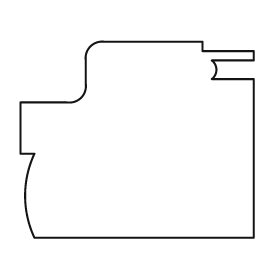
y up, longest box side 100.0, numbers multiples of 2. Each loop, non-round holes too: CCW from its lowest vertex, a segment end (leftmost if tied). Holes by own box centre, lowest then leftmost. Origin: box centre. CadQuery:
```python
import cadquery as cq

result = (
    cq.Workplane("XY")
    .moveTo(-44.0, -42.0)
    .lineTo(50.0, -42.0)
    .lineTo(50.0, 26.0)
    .lineTo(32.0, 26.0)
    .threePointArc((34.0, 30.0), (32.0, 34.0))
    .lineTo(50.0, 34.0)
    .lineTo(50.0, 38.0)
    .lineTo(28.0, 38.0)
    .lineTo(28.0, 42.0)
    .lineTo(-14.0, 42.0)
    .threePointArc((-20.0, 40.0), (-22.0, 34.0))
    .lineTo(-22.0, 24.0)
    .threePointArc((-24.0, 18.0), (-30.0, 16.0))
    .lineTo(-50.0, 16.0)
    .lineTo(-50.0, -6.0)
    .lineTo(-44.0, -6.0)
    .threePointArc((-48.0, -24.0), (-44.0, -42.0))
    .close()
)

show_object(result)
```